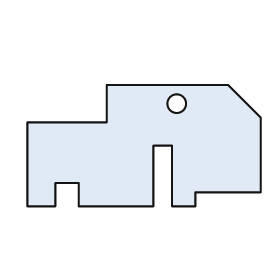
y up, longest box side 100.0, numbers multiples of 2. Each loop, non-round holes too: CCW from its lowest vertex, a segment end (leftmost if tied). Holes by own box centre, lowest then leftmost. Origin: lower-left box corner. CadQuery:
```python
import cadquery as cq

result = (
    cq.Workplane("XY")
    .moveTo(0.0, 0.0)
    .lineTo(12.0, 0.0)
    .lineTo(12.0, 10.0)
    .lineTo(22.0, 10.0)
    .lineTo(22.0, 0.0)
    .lineTo(54.0, 0.0)
    .lineTo(54.0, 26.0)
    .lineTo(62.0, 26.0)
    .lineTo(62.0, 0.0)
    .lineTo(72.0, 0.0)
    .lineTo(72.0, 6.0)
    .lineTo(100.0, 6.0)
    .lineTo(100.0, 38.0)
    .lineTo(86.0, 52.0)
    .lineTo(34.0, 52.0)
    .lineTo(34.0, 36.0)
    .lineTo(0.0, 36.0)
    .close()
    .moveTo(64.0, 44.0)
    .circle(4.0)
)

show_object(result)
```